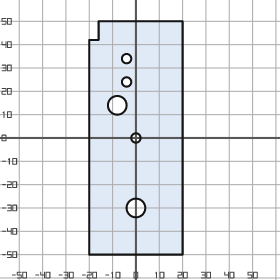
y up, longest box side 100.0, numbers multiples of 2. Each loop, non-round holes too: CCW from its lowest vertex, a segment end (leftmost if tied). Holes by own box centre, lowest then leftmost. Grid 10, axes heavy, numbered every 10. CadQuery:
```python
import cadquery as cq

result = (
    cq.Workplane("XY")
    .moveTo(-20.0, -50.0)
    .lineTo(20.0, -50.0)
    .lineTo(20.0, 50.0)
    .lineTo(-16.0, 50.0)
    .lineTo(-16.0, 42.0)
    .lineTo(-20.0, 42.0)
    .close()
    .moveTo(0.0, -30.0)
    .circle(4.0)
    .moveTo(0.0, 0.0)
    .circle(2.0)
    .moveTo(-8.0, 14.0)
    .circle(4.0)
    .moveTo(-4.0, 24.0)
    .circle(2.0)
    .moveTo(-4.0, 34.0)
    .circle(2.0)
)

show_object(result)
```